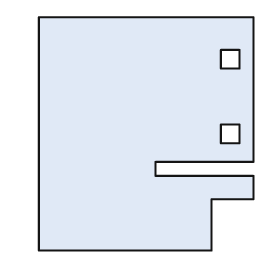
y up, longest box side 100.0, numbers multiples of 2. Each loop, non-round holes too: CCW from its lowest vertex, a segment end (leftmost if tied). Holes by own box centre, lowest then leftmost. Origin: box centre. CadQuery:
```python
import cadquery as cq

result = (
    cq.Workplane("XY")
    .moveTo(-46.0, -50.0)
    .lineTo(28.0, -50.0)
    .lineTo(28.0, -28.0)
    .lineTo(46.0, -28.0)
    .lineTo(46.0, -18.0)
    .lineTo(4.0, -18.0)
    .lineTo(4.0, -12.0)
    .lineTo(46.0, -12.0)
    .lineTo(46.0, 50.0)
    .lineTo(-46.0, 50.0)
    .close()
    .moveTo(32.0, -4.0)
    .lineTo(40.0, -4.0)
    .lineTo(40.0, 4.0)
    .lineTo(32.0, 4.0)
    .close()
    .moveTo(32.0, 28.0)
    .lineTo(40.0, 28.0)
    .lineTo(40.0, 36.0)
    .lineTo(32.0, 36.0)
    .close()
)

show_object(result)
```